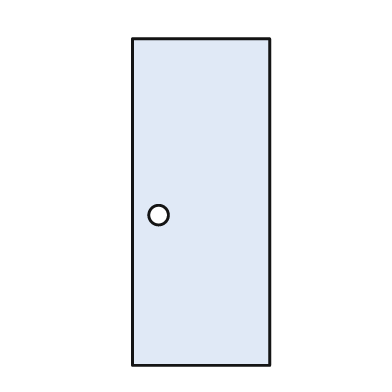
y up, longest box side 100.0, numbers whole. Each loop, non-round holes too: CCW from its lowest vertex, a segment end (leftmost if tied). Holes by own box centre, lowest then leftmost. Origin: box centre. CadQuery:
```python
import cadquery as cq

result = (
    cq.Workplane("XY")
    .moveTo(-21.0, -50.0)
    .lineTo(21.0, -50.0)
    .lineTo(21.0, 50.0)
    .lineTo(-21.0, 50.0)
    .close()
    .moveTo(-13.0, -4.0)
    .circle(3.0)
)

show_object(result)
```